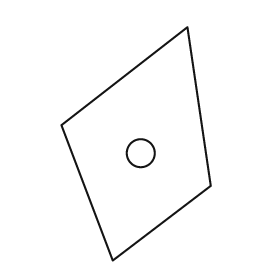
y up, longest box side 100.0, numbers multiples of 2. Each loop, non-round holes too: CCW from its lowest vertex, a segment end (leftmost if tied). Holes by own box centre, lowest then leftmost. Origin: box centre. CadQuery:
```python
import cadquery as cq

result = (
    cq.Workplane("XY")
    .moveTo(-10.0, -50.0)
    .lineTo(32.0, -18.0)
    .lineTo(22.0, 50.0)
    .lineTo(-32.0, 8.0)
    .close()
    .moveTo(2.0, -4.0)
    .circle(6.0)
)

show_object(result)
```